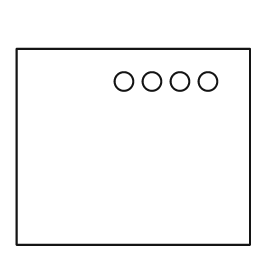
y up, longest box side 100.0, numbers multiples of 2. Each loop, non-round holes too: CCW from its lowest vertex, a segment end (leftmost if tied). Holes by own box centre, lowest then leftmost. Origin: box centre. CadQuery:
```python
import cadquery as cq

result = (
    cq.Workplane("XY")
    .moveTo(-50.0, -42.0)
    .lineTo(50.0, -42.0)
    .lineTo(50.0, 42.0)
    .lineTo(-50.0, 42.0)
    .close()
    .moveTo(-4.0, 28.0)
    .circle(4.0)
    .moveTo(8.0, 28.0)
    .circle(4.0)
    .moveTo(20.0, 28.0)
    .circle(4.0)
    .moveTo(32.0, 28.0)
    .circle(4.0)
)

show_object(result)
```